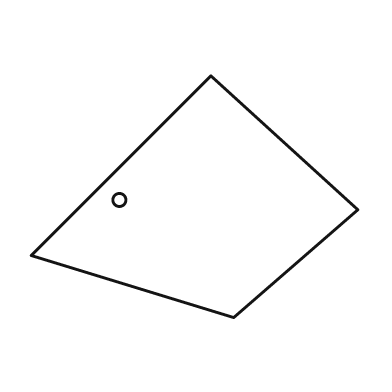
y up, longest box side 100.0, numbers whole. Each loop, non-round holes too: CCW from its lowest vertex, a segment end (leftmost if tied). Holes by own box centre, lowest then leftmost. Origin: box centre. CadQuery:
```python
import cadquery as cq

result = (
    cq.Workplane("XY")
    .moveTo(12.0, -37.0)
    .lineTo(50.0, -4.0)
    .lineTo(5.0, 37.0)
    .lineTo(-50.0, -18.0)
    .close()
    .moveTo(-23.0, -1.0)
    .circle(2.0)
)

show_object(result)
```